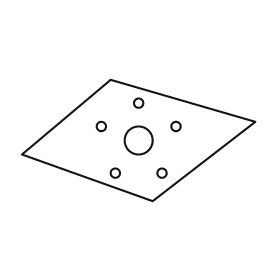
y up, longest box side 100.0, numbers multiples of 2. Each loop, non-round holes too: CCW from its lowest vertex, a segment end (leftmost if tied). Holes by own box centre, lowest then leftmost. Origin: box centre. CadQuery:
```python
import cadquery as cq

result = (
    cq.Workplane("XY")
    .moveTo(6.0, -26.0)
    .lineTo(50.0, 8.0)
    .lineTo(-12.0, 26.0)
    .lineTo(-50.0, -6.0)
    .close()
    .moveTo(-10.0, -14.0)
    .circle(2.0)
    .moveTo(10.0, -14.0)
    .circle(2.0)
    .moveTo(0.0, 0.0)
    .circle(6.0)
    .moveTo(-16.0, 6.0)
    .circle(2.0)
    .moveTo(16.0, 6.0)
    .circle(2.0)
    .moveTo(0.0, 16.0)
    .circle(2.0)
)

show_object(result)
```